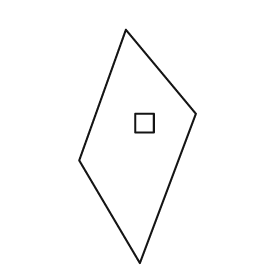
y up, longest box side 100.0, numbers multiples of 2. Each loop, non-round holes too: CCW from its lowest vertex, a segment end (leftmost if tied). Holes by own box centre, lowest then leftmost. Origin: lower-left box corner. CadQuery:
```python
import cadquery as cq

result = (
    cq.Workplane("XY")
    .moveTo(26.0, 0.0)
    .lineTo(50.0, 64.0)
    .lineTo(20.0, 100.0)
    .lineTo(0.0, 44.0)
    .close()
    .moveTo(24.0, 56.0)
    .lineTo(32.0, 56.0)
    .lineTo(32.0, 64.0)
    .lineTo(24.0, 64.0)
    .close()
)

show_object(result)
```